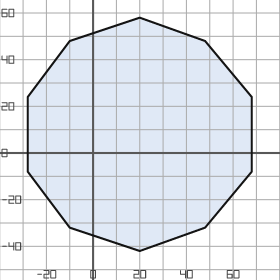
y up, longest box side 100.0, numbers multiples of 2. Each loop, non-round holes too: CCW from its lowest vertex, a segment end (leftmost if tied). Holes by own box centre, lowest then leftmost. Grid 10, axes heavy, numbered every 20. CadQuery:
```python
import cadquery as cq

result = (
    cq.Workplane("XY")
    .moveTo(20.0, -42.0)
    .lineTo(48.0, -32.0)
    .lineTo(68.0, -8.0)
    .lineTo(68.0, 24.0)
    .lineTo(48.0, 48.0)
    .lineTo(20.0, 58.0)
    .lineTo(-10.0, 48.0)
    .lineTo(-28.0, 24.0)
    .lineTo(-28.0, -8.0)
    .lineTo(-10.0, -32.0)
    .close()
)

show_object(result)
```